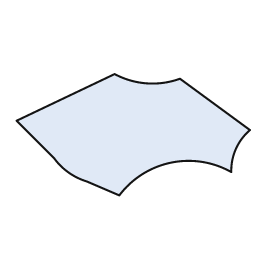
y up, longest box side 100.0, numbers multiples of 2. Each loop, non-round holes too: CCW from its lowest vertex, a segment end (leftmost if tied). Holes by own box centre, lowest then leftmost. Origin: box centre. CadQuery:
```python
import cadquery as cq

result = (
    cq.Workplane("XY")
    .moveTo(-6.0, -26.0)
    .threePointArc((16.0, -12.0), (42.0, -16.0))
    .threePointArc((44.0, -6.0), (50.0, 2.0))
    .lineTo(20.0, 24.0)
    .threePointArc((6.0, 22.0), (-8.0, 26.0))
    .lineTo(-50.0, 6.0)
    .lineTo(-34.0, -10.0)
    .threePointArc((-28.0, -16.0), (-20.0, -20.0))
    .close()
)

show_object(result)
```